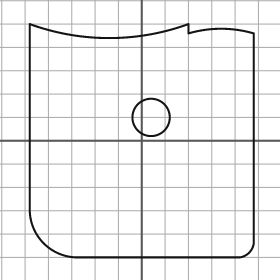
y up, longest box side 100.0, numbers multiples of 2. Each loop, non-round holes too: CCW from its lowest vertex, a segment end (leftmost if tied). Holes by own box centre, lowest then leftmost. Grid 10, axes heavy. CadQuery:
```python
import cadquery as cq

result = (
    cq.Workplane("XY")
    .moveTo(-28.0, -50.0)
    .lineTo(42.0, -50.0)
    .threePointArc((46.0, -48.0), (48.0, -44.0))
    .lineTo(48.0, 46.0)
    .threePointArc((34.0, 48.0), (20.0, 46.0))
    .lineTo(20.0, 50.0)
    .threePointArc((-14.0, 44.0), (-48.0, 50.0))
    .lineTo(-48.0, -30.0)
    .threePointArc((-42.0, -44.0), (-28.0, -50.0))
    .close()
    .moveTo(4.0, 10.0)
    .circle(8.0)
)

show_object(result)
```